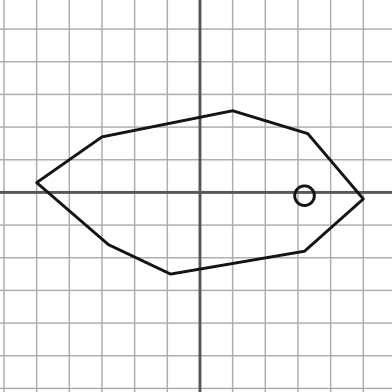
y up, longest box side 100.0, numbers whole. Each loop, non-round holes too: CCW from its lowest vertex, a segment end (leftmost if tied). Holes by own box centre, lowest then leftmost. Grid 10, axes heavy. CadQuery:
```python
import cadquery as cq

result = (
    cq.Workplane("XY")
    .moveTo(-9.0, -25.0)
    .lineTo(32.0, -18.0)
    .lineTo(50.0, -2.0)
    .lineTo(33.0, 18.0)
    .lineTo(10.0, 25.0)
    .lineTo(-30.0, 17.0)
    .lineTo(-50.0, 3.0)
    .lineTo(-28.0, -16.0)
    .close()
    .moveTo(32.0, -1.0)
    .circle(3.0)
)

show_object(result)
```